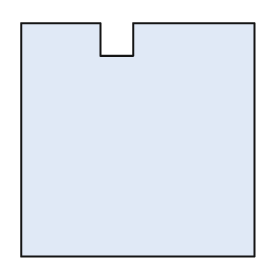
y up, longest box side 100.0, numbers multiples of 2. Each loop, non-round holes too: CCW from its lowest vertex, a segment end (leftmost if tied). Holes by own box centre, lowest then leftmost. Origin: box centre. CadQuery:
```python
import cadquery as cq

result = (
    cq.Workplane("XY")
    .moveTo(-50.0, -50.0)
    .lineTo(50.0, -50.0)
    .lineTo(50.0, 50.0)
    .lineTo(-2.0, 50.0)
    .lineTo(-2.0, 36.0)
    .lineTo(-16.0, 36.0)
    .lineTo(-16.0, 50.0)
    .lineTo(-50.0, 50.0)
    .close()
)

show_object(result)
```